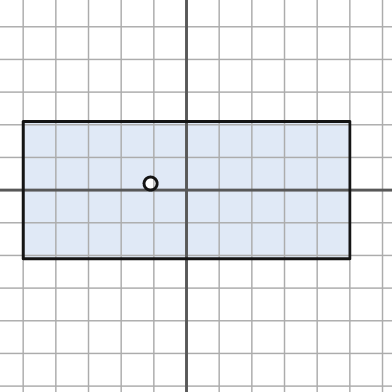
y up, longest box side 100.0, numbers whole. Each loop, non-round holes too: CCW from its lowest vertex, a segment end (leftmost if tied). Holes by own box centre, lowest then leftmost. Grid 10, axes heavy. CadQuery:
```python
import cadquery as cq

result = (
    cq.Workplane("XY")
    .moveTo(-50.0, -21.0)
    .lineTo(50.0, -21.0)
    .lineTo(50.0, 21.0)
    .lineTo(-50.0, 21.0)
    .close()
    .moveTo(-11.0, 2.0)
    .circle(2.0)
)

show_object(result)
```